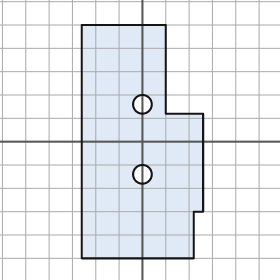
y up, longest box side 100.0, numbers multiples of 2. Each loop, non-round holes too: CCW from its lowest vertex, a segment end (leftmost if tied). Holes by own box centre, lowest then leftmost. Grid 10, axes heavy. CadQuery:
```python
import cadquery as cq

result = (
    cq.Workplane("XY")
    .moveTo(-26.0, -50.0)
    .lineTo(22.0, -50.0)
    .lineTo(22.0, -30.0)
    .lineTo(26.0, -30.0)
    .lineTo(26.0, 12.0)
    .lineTo(10.0, 12.0)
    .lineTo(10.0, 50.0)
    .lineTo(-26.0, 50.0)
    .close()
    .moveTo(0.0, -14.0)
    .circle(4.0)
    .moveTo(0.0, 16.0)
    .circle(4.0)
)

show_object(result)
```